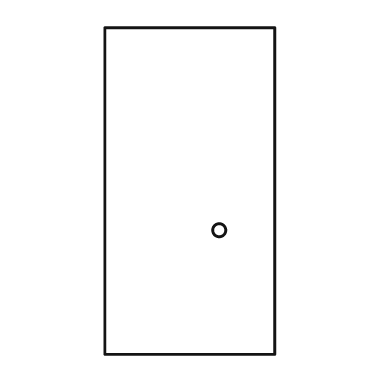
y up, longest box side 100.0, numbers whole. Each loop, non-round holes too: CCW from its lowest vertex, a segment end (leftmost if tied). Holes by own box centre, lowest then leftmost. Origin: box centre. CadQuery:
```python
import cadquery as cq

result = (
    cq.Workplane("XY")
    .moveTo(-26.0, -50.0)
    .lineTo(26.0, -50.0)
    .lineTo(26.0, 50.0)
    .lineTo(-26.0, 50.0)
    .close()
    .moveTo(9.0, -12.0)
    .circle(2.0)
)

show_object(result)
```